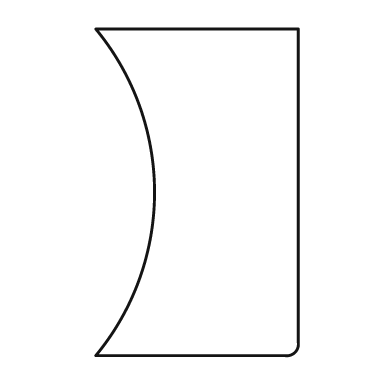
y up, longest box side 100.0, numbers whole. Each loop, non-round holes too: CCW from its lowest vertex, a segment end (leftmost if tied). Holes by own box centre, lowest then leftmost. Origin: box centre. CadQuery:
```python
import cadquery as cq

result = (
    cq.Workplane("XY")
    .moveTo(-31.0, -50.0)
    .lineTo(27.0, -50.0)
    .threePointArc((30.0, -49.0), (31.0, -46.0))
    .lineTo(31.0, 50.0)
    .lineTo(-31.0, 50.0)
    .threePointArc((-13.0, 0.0), (-31.0, -50.0))
    .close()
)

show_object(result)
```